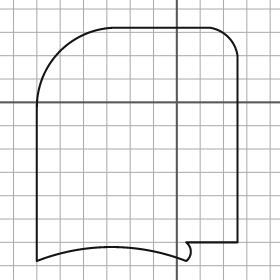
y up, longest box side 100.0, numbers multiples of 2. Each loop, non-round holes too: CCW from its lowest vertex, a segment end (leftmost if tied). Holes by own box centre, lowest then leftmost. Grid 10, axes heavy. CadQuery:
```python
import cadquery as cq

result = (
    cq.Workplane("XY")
    .moveTo(-60.0, -68.0)
    .threePointArc((-28.0, -62.0), (4.0, -68.0))
    .threePointArc((6.0, -64.0), (4.0, -60.0))
    .lineTo(26.0, -60.0)
    .lineTo(26.0, 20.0)
    .threePointArc((22.0, 28.0), (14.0, 32.0))
    .lineTo(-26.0, 32.0)
    .threePointArc((-50.0, 22.0), (-60.0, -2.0))
    .close()
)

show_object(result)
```